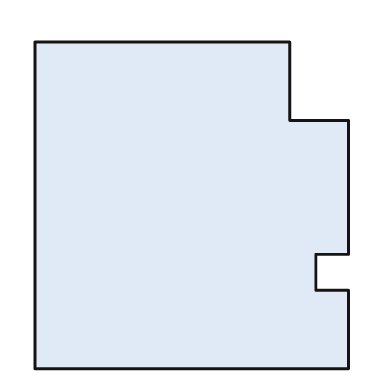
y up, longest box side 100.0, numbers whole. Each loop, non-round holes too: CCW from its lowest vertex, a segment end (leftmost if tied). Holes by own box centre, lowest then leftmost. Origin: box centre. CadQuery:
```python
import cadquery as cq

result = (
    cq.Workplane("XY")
    .moveTo(-48.0, -50.0)
    .lineTo(48.0, -50.0)
    .lineTo(48.0, -26.0)
    .lineTo(38.0, -26.0)
    .lineTo(38.0, -15.0)
    .lineTo(48.0, -15.0)
    .lineTo(48.0, 26.0)
    .lineTo(30.0, 26.0)
    .lineTo(30.0, 50.0)
    .lineTo(-48.0, 50.0)
    .close()
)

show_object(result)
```